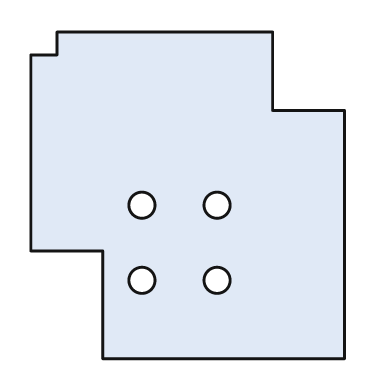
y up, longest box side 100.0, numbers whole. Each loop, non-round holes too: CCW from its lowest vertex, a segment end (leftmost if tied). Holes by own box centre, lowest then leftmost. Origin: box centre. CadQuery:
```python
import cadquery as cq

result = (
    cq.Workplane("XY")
    .moveTo(-26.0, -50.0)
    .lineTo(48.0, -50.0)
    .lineTo(48.0, 26.0)
    .lineTo(26.0, 26.0)
    .lineTo(26.0, 50.0)
    .lineTo(-40.0, 50.0)
    .lineTo(-40.0, 43.0)
    .lineTo(-48.0, 43.0)
    .lineTo(-48.0, -17.0)
    .lineTo(-26.0, -17.0)
    .close()
    .moveTo(-14.0, -26.0)
    .circle(4.0)
    .moveTo(9.0, -26.0)
    .circle(4.0)
    .moveTo(-14.0, -3.0)
    .circle(4.0)
    .moveTo(9.0, -3.0)
    .circle(4.0)
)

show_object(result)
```